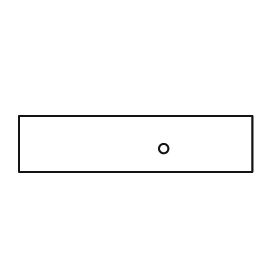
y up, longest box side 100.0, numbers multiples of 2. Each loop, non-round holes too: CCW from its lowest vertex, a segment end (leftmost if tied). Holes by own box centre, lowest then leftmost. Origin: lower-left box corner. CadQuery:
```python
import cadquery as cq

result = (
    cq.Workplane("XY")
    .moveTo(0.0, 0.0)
    .lineTo(100.0, 0.0)
    .lineTo(100.0, 24.0)
    .lineTo(0.0, 24.0)
    .close()
    .moveTo(62.0, 10.0)
    .circle(2.0)
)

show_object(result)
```